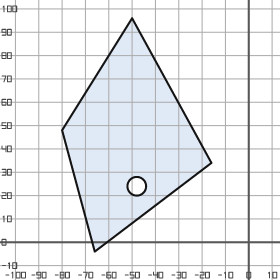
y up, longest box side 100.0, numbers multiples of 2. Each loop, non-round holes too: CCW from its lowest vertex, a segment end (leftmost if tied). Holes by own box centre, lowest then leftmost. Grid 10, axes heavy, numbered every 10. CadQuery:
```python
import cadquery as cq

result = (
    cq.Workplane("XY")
    .moveTo(-66.0, -4.0)
    .lineTo(-16.0, 34.0)
    .lineTo(-50.0, 96.0)
    .lineTo(-80.0, 48.0)
    .close()
    .moveTo(-48.0, 24.0)
    .circle(4.0)
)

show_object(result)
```